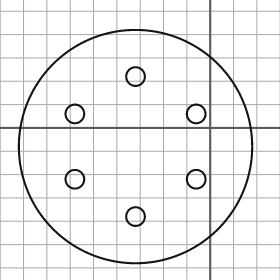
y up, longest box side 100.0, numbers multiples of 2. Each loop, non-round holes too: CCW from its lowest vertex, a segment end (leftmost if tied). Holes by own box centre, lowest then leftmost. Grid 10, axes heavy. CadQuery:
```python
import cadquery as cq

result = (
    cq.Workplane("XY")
    .moveTo(-32.0, -8.0)
    .circle(50.0)
    .moveTo(-32.0, -38.0)
    .circle(4.0)
    .moveTo(-58.0, -22.0)
    .circle(4.0)
    .moveTo(-6.0, -22.0)
    .circle(4.0)
    .moveTo(-58.0, 6.0)
    .circle(4.0)
    .moveTo(-6.0, 6.0)
    .circle(4.0)
    .moveTo(-32.0, 22.0)
    .circle(4.0)
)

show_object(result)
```